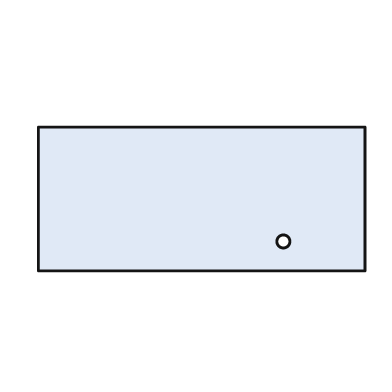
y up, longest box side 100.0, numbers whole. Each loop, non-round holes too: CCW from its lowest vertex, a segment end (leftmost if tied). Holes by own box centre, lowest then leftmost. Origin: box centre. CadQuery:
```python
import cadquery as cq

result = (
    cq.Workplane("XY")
    .moveTo(-50.0, -22.0)
    .lineTo(50.0, -22.0)
    .lineTo(50.0, 22.0)
    .lineTo(-50.0, 22.0)
    .close()
    .moveTo(25.0, -13.0)
    .circle(2.0)
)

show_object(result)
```